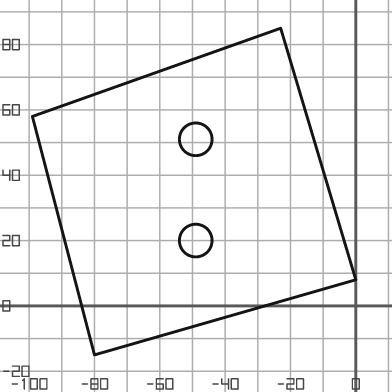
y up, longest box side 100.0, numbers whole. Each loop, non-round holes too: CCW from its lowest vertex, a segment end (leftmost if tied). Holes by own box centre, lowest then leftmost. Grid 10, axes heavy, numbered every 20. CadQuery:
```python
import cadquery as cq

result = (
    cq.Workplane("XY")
    .moveTo(-80.0, -15.0)
    .lineTo(0.0, 8.0)
    .lineTo(-23.0, 85.0)
    .lineTo(-99.0, 58.0)
    .close()
    .moveTo(-49.0, 20.0)
    .circle(5.0)
    .moveTo(-49.0, 51.0)
    .circle(5.0)
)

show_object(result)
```